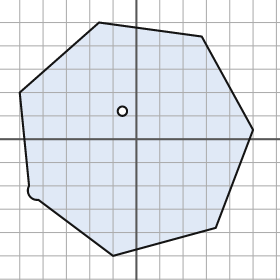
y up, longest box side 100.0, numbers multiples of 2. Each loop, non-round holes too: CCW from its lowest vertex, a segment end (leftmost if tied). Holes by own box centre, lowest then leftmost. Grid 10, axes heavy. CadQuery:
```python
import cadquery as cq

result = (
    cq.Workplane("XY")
    .moveTo(-10.0, -50.0)
    .lineTo(34.0, -38.0)
    .lineTo(50.0, 4.0)
    .lineTo(28.0, 44.0)
    .lineTo(-16.0, 50.0)
    .lineTo(-50.0, 20.0)
    .lineTo(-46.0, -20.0)
    .threePointArc((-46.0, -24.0), (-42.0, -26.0))
    .close()
    .moveTo(-6.0, 12.0)
    .circle(2.0)
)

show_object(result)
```